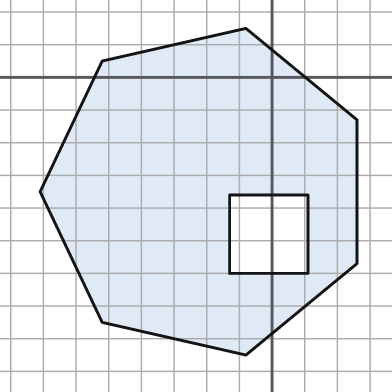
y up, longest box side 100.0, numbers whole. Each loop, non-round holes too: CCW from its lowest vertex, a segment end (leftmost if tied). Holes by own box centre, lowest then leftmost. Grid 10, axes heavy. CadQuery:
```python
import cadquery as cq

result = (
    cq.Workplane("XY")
    .moveTo(-8.0, -85.0)
    .lineTo(26.0, -57.0)
    .lineTo(26.0, -13.0)
    .lineTo(-8.0, 15.0)
    .lineTo(-52.0, 5.0)
    .lineTo(-71.0, -35.0)
    .lineTo(-52.0, -75.0)
    .close()
    .moveTo(-13.0, -60.0)
    .lineTo(11.0, -60.0)
    .lineTo(11.0, -36.0)
    .lineTo(-13.0, -36.0)
    .close()
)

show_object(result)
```